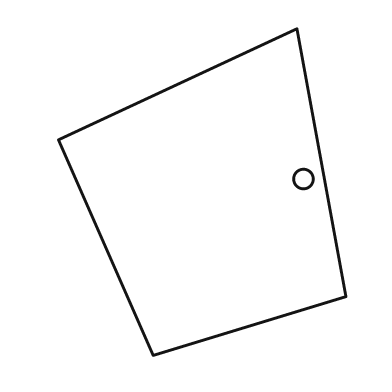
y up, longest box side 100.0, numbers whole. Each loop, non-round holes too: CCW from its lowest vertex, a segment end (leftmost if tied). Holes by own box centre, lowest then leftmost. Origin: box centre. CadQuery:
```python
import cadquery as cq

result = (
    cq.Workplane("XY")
    .moveTo(-15.0, -50.0)
    .lineTo(44.0, -32.0)
    .lineTo(29.0, 50.0)
    .lineTo(-44.0, 16.0)
    .close()
    .moveTo(31.0, 4.0)
    .circle(3.0)
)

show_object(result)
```